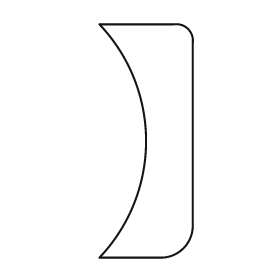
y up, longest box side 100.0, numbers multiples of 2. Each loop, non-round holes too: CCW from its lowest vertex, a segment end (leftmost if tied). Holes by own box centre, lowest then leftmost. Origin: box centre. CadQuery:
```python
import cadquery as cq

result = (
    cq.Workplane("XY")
    .moveTo(-20.0, -50.0)
    .lineTo(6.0, -50.0)
    .threePointArc((16.0, -46.0), (20.0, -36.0))
    .lineTo(20.0, 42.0)
    .threePointArc((18.0, 48.0), (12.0, 50.0))
    .lineTo(-20.0, 50.0)
    .threePointArc((0.0, 0.0), (-20.0, -50.0))
    .close()
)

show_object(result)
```